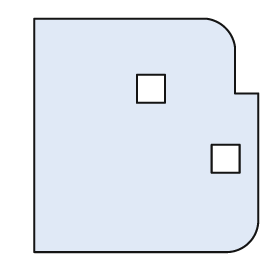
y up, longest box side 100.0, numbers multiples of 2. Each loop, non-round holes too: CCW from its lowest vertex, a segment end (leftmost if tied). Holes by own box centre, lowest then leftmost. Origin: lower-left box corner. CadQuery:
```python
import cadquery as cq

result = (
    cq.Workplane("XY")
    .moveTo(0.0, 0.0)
    .lineTo(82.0, 0.0)
    .threePointArc((92.0, 4.0), (96.0, 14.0))
    .lineTo(96.0, 68.0)
    .lineTo(86.0, 68.0)
    .lineTo(86.0, 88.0)
    .threePointArc((82.0, 96.0), (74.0, 100.0))
    .lineTo(0.0, 100.0)
    .close()
    .moveTo(76.0, 34.0)
    .lineTo(88.0, 34.0)
    .lineTo(88.0, 46.0)
    .lineTo(76.0, 46.0)
    .close()
    .moveTo(44.0, 64.0)
    .lineTo(56.0, 64.0)
    .lineTo(56.0, 76.0)
    .lineTo(44.0, 76.0)
    .close()
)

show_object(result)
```